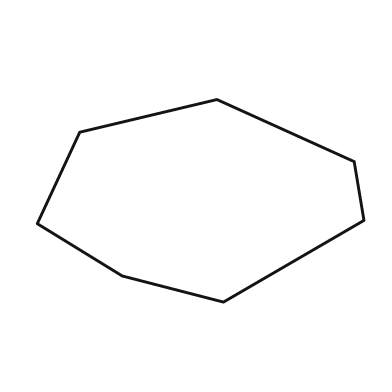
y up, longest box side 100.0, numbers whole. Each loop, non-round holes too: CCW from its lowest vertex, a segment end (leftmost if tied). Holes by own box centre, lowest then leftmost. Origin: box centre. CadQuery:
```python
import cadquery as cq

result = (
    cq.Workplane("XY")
    .moveTo(7.0, -31.0)
    .lineTo(50.0, -6.0)
    .lineTo(47.0, 12.0)
    .lineTo(5.0, 31.0)
    .lineTo(-37.0, 21.0)
    .lineTo(-50.0, -7.0)
    .lineTo(-24.0, -23.0)
    .close()
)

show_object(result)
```